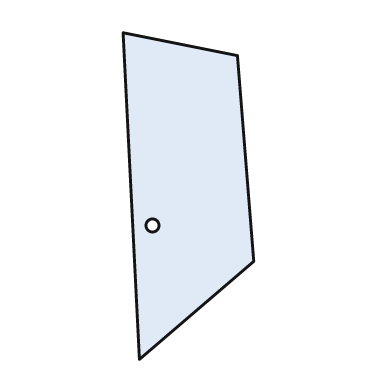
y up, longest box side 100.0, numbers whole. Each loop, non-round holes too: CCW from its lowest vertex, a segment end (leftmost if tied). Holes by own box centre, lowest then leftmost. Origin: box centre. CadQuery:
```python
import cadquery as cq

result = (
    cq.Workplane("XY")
    .moveTo(-15.0, -50.0)
    .lineTo(20.0, -20.0)
    .lineTo(15.0, 43.0)
    .lineTo(-20.0, 50.0)
    .close()
    .moveTo(-11.0, -9.0)
    .circle(2.0)
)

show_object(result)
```